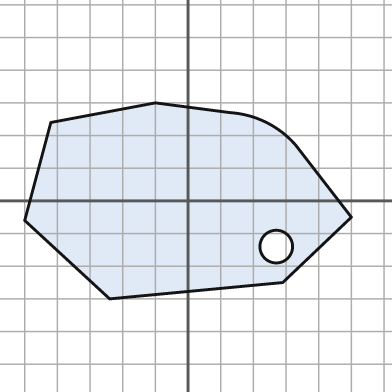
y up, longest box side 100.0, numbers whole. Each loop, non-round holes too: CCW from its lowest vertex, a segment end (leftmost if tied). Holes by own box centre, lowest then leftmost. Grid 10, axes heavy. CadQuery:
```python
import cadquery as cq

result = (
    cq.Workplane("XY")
    .moveTo(-24.0, -30.0)
    .lineTo(29.0, -25.0)
    .lineTo(50.0, -5.0)
    .lineTo(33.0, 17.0)
    .threePointArc((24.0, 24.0), (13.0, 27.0))
    .lineTo(-10.0, 30.0)
    .lineTo(-42.0, 24.0)
    .lineTo(-50.0, -6.0)
    .close()
    .moveTo(27.0, -14.0)
    .circle(5.0)
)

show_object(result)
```